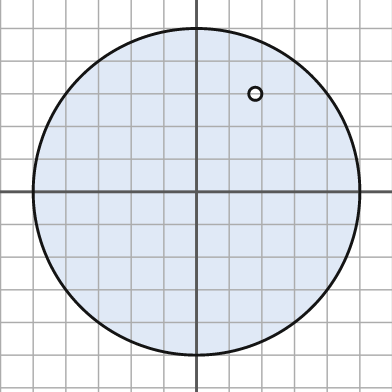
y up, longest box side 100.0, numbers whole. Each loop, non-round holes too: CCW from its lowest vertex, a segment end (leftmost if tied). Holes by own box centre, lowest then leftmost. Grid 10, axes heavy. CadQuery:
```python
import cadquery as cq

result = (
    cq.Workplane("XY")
    .moveTo(0.0, 0.0)
    .circle(50.0)
    .moveTo(18.0, 30.0)
    .circle(2.0)
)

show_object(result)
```